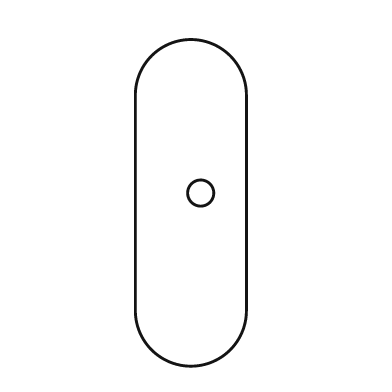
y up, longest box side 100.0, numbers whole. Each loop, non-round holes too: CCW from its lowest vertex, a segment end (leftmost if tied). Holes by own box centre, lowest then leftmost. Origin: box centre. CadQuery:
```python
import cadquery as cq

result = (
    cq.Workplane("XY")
    .moveTo(-17.0, -33.0)
    .threePointArc((0.0, -50.0), (17.0, -33.0))
    .lineTo(17.0, 33.0)
    .threePointArc((0.0, 50.0), (-17.0, 33.0))
    .close()
    .moveTo(3.0, 3.0)
    .circle(4.0)
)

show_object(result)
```